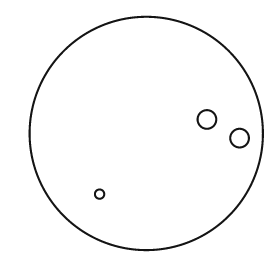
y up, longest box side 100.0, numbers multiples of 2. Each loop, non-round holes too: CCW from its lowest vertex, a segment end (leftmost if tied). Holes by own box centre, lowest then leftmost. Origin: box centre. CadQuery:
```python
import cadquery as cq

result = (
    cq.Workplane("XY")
    .moveTo(0.0, 0.0)
    .circle(50.0)
    .moveTo(-20.0, -26.0)
    .circle(2.0)
    .moveTo(40.0, -2.0)
    .circle(4.0)
    .moveTo(26.0, 6.0)
    .circle(4.0)
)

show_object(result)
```